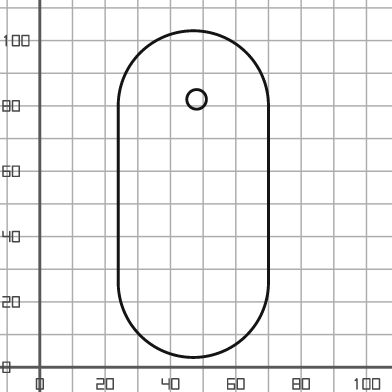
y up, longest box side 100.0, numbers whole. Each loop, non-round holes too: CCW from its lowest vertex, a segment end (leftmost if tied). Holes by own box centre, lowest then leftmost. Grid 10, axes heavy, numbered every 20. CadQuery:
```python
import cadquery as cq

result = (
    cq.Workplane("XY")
    .moveTo(24.0, 26.0)
    .threePointArc((47.0, 3.0), (70.0, 26.0))
    .lineTo(70.0, 80.0)
    .threePointArc((47.0, 103.0), (24.0, 80.0))
    .close()
    .moveTo(48.0, 82.0)
    .circle(3.0)
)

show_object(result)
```